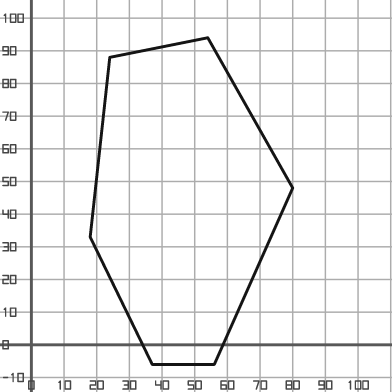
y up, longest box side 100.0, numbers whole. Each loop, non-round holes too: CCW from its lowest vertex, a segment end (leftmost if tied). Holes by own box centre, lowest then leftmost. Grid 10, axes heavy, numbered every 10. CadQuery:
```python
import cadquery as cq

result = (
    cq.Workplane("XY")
    .moveTo(37.0, -6.0)
    .lineTo(56.0, -6.0)
    .lineTo(80.0, 48.0)
    .lineTo(54.0, 94.0)
    .lineTo(24.0, 88.0)
    .lineTo(18.0, 33.0)
    .close()
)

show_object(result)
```